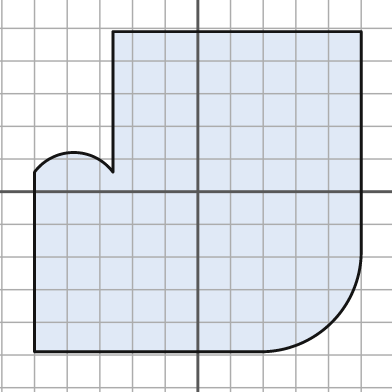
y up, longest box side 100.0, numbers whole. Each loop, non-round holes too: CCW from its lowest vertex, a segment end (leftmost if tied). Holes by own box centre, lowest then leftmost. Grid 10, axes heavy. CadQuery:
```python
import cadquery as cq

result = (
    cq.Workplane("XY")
    .moveTo(-50.0, -49.0)
    .lineTo(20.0, -49.0)
    .threePointArc((41.0, -40.0), (50.0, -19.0))
    .lineTo(50.0, 49.0)
    .lineTo(-26.0, 49.0)
    .lineTo(-26.0, 6.0)
    .threePointArc((-38.0, 12.0), (-50.0, 6.0))
    .close()
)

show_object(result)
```